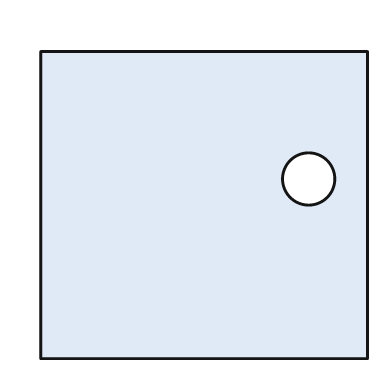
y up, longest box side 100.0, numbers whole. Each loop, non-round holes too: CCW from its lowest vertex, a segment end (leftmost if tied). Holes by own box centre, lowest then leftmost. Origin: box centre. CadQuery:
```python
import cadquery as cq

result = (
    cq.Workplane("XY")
    .moveTo(-50.0, -47.0)
    .lineTo(50.0, -47.0)
    .lineTo(50.0, 47.0)
    .lineTo(-50.0, 47.0)
    .close()
    .moveTo(32.0, 8.0)
    .circle(8.0)
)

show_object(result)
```